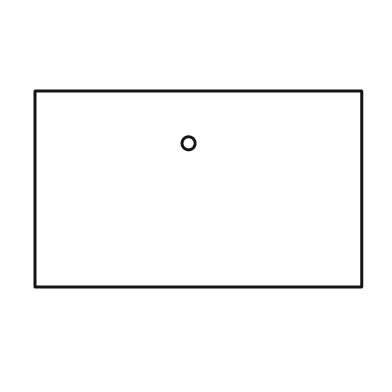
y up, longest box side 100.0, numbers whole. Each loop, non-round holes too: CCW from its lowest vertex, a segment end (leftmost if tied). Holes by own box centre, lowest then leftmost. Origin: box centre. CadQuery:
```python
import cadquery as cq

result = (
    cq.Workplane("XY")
    .moveTo(-50.0, -30.0)
    .lineTo(50.0, -30.0)
    .lineTo(50.0, 30.0)
    .lineTo(-50.0, 30.0)
    .close()
    .moveTo(-3.0, 14.0)
    .circle(2.0)
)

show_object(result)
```